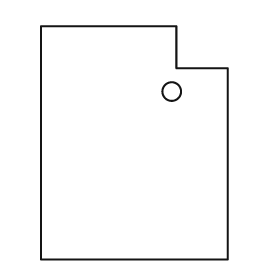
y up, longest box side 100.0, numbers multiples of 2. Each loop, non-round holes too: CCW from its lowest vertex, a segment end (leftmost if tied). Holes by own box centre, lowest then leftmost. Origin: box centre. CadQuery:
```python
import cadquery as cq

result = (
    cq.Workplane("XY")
    .moveTo(-40.0, -50.0)
    .lineTo(40.0, -50.0)
    .lineTo(40.0, 32.0)
    .lineTo(18.0, 32.0)
    .lineTo(18.0, 50.0)
    .lineTo(-40.0, 50.0)
    .close()
    .moveTo(16.0, 22.0)
    .circle(4.0)
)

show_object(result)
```